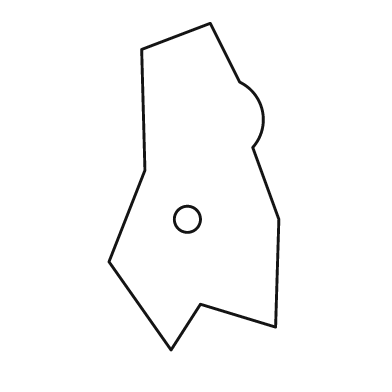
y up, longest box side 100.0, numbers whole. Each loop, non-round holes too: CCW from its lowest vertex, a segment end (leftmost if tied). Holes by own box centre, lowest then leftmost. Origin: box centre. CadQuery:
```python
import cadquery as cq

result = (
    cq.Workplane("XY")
    .moveTo(-7.0, -50.0)
    .lineTo(2.0, -36.0)
    .lineTo(25.0, -43.0)
    .lineTo(26.0, -10.0)
    .lineTo(18.0, 12.0)
    .threePointArc((21.0, 23.0), (14.0, 32.0))
    .lineTo(5.0, 50.0)
    .lineTo(-16.0, 42.0)
    .lineTo(-15.0, 5.0)
    .lineTo(-26.0, -23.0)
    .close()
    .moveTo(-2.0, -10.0)
    .circle(4.0)
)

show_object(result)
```